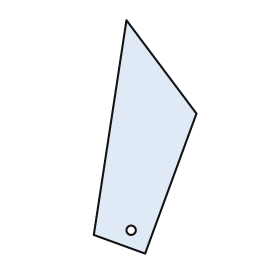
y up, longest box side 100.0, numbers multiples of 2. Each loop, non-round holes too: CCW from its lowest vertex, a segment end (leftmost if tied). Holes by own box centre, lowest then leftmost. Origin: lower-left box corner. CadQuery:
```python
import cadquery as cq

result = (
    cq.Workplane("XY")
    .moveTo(22.0, 0.0)
    .lineTo(44.0, 60.0)
    .lineTo(14.0, 100.0)
    .lineTo(0.0, 8.0)
    .close()
    .moveTo(16.0, 10.0)
    .circle(2.0)
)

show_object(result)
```